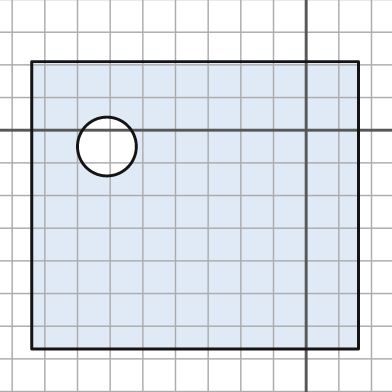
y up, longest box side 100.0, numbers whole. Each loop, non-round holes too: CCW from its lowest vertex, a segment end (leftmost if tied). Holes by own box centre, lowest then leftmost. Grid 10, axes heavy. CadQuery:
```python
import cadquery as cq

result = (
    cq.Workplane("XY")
    .moveTo(-84.0, -67.0)
    .lineTo(16.0, -67.0)
    .lineTo(16.0, 21.0)
    .lineTo(-84.0, 21.0)
    .close()
    .moveTo(-61.0, -5.0)
    .circle(9.0)
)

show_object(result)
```